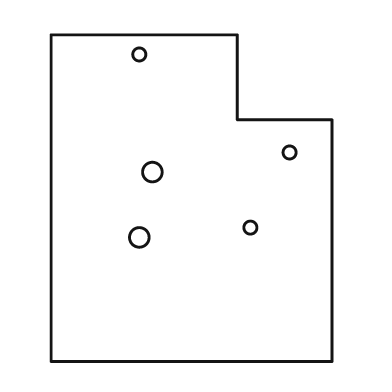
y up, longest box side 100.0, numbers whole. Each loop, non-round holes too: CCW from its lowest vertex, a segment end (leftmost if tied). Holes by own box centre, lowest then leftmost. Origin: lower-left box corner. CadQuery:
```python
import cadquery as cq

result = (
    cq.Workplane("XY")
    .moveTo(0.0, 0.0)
    .lineTo(86.0, 0.0)
    .lineTo(86.0, 74.0)
    .lineTo(57.0, 74.0)
    .lineTo(57.0, 100.0)
    .lineTo(0.0, 100.0)
    .close()
    .moveTo(27.0, 38.0)
    .circle(3.0)
    .moveTo(61.0, 41.0)
    .circle(2.0)
    .moveTo(31.0, 58.0)
    .circle(3.0)
    .moveTo(73.0, 64.0)
    .circle(2.0)
    .moveTo(27.0, 94.0)
    .circle(2.0)
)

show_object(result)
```